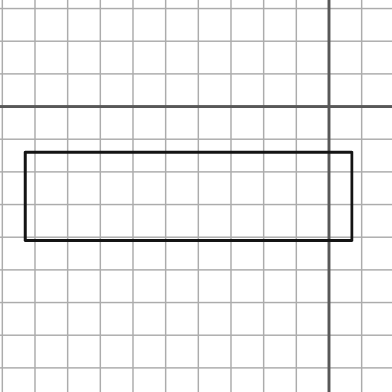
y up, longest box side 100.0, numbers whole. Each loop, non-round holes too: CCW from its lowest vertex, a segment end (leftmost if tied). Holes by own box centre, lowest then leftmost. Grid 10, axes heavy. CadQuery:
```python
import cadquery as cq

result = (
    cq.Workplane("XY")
    .moveTo(-93.0, -41.0)
    .lineTo(7.0, -41.0)
    .lineTo(7.0, -14.0)
    .lineTo(-93.0, -14.0)
    .close()
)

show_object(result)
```